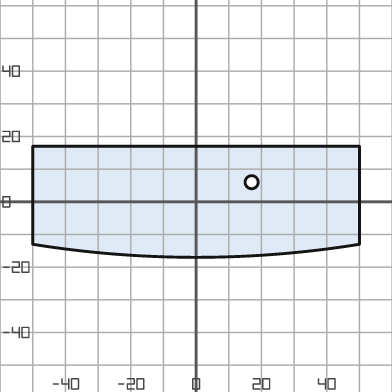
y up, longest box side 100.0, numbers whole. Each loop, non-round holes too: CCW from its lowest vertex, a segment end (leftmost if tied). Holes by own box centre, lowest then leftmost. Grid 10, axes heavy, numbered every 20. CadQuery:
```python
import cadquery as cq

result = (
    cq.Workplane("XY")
    .moveTo(-50.0, -13.0)
    .threePointArc((0.0, -17.0), (50.0, -13.0))
    .lineTo(50.0, 17.0)
    .lineTo(-50.0, 17.0)
    .close()
    .moveTo(17.0, 6.0)
    .circle(2.0)
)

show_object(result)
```